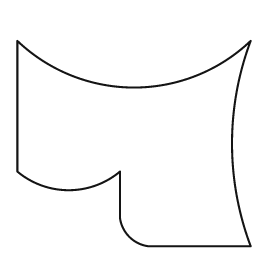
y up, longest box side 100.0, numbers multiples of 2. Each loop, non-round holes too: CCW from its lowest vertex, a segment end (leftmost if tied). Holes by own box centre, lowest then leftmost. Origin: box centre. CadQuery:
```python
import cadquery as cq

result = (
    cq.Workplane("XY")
    .moveTo(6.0, -44.0)
    .lineTo(50.0, -44.0)
    .threePointArc((42.0, 0.0), (50.0, 44.0))
    .threePointArc((0.0, 24.0), (-50.0, 44.0))
    .lineTo(-50.0, -12.0)
    .threePointArc((-28.0, -20.0), (-6.0, -12.0))
    .lineTo(-6.0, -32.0)
    .threePointArc((-2.0, -40.0), (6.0, -44.0))
    .close()
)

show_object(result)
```